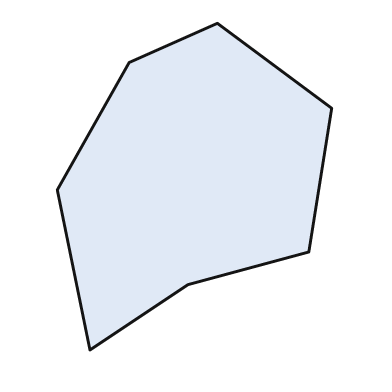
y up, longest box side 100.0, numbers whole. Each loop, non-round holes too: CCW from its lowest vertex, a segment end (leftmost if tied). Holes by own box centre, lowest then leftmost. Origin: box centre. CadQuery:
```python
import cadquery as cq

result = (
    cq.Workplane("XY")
    .moveTo(-32.0, -50.0)
    .lineTo(-2.0, -30.0)
    .lineTo(35.0, -20.0)
    .lineTo(42.0, 24.0)
    .lineTo(7.0, 50.0)
    .lineTo(-20.0, 38.0)
    .lineTo(-42.0, -1.0)
    .close()
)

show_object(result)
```